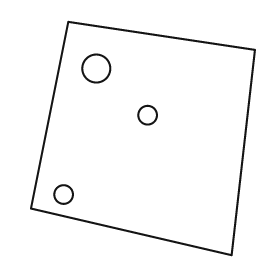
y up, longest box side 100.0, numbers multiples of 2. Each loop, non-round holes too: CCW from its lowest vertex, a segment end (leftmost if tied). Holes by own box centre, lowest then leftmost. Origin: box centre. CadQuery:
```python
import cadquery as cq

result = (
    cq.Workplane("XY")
    .moveTo(38.0, -50.0)
    .lineTo(48.0, 38.0)
    .lineTo(-32.0, 50.0)
    .lineTo(-48.0, -30.0)
    .close()
    .moveTo(-34.0, -24.0)
    .circle(4.0)
    .moveTo(2.0, 10.0)
    .circle(4.0)
    .moveTo(-20.0, 30.0)
    .circle(6.0)
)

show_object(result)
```